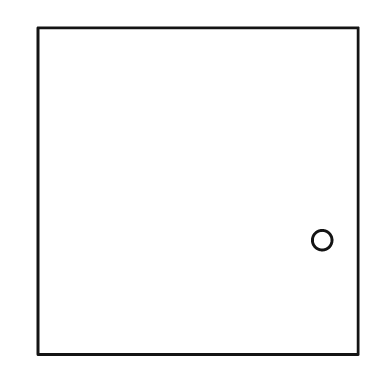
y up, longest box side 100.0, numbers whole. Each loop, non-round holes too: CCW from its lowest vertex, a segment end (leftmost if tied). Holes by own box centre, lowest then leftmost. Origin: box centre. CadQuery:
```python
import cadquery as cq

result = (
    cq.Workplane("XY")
    .moveTo(-49.0, -50.0)
    .lineTo(49.0, -50.0)
    .lineTo(49.0, 50.0)
    .lineTo(-49.0, 50.0)
    .close()
    .moveTo(38.0, -15.0)
    .circle(3.0)
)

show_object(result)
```